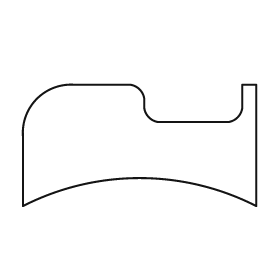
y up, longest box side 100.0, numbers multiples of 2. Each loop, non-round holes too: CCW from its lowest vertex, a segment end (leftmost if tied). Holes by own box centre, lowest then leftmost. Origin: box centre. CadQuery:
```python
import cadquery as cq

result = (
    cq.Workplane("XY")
    .moveTo(-50.0, -26.0)
    .threePointArc((0.0, -14.0), (50.0, -26.0))
    .lineTo(50.0, 26.0)
    .lineTo(44.0, 26.0)
    .lineTo(44.0, 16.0)
    .threePointArc((42.0, 12.0), (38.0, 10.0))
    .lineTo(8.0, 10.0)
    .threePointArc((4.0, 12.0), (2.0, 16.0))
    .lineTo(2.0, 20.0)
    .threePointArc((0.0, 24.0), (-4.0, 26.0))
    .lineTo(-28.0, 26.0)
    .threePointArc((-44.0, 20.0), (-50.0, 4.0))
    .close()
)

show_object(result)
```